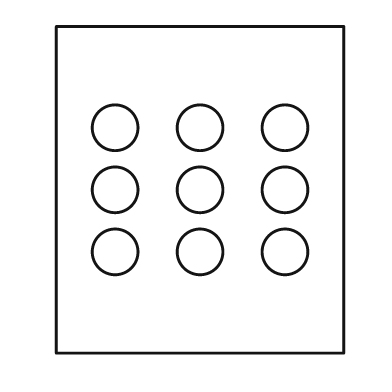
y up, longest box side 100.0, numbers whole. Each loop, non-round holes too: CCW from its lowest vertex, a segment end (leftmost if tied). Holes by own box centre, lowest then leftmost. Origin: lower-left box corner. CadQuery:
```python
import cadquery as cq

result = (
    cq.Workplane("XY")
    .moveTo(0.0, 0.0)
    .lineTo(88.0, 0.0)
    .lineTo(88.0, 100.0)
    .lineTo(0.0, 100.0)
    .close()
    .moveTo(18.0, 31.0)
    .circle(7.0)
    .moveTo(44.0, 31.0)
    .circle(7.0)
    .moveTo(70.0, 31.0)
    .circle(7.0)
    .moveTo(18.0, 50.0)
    .circle(7.0)
    .moveTo(44.0, 50.0)
    .circle(7.0)
    .moveTo(70.0, 50.0)
    .circle(7.0)
    .moveTo(18.0, 69.0)
    .circle(7.0)
    .moveTo(44.0, 69.0)
    .circle(7.0)
    .moveTo(70.0, 69.0)
    .circle(7.0)
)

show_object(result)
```